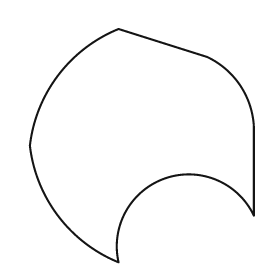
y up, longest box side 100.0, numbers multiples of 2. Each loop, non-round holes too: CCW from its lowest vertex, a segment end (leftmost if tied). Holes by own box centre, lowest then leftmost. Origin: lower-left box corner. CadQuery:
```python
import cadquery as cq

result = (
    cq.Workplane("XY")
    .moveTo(38.0, 0.0)
    .threePointArc((58.0, 36.0), (96.0, 20.0))
    .lineTo(96.0, 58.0)
    .threePointArc((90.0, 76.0), (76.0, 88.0))
    .lineTo(38.0, 100.0)
    .threePointArc((12.0, 80.0), (0.0, 50.0))
    .threePointArc((12.0, 20.0), (38.0, 0.0))
    .close()
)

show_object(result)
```